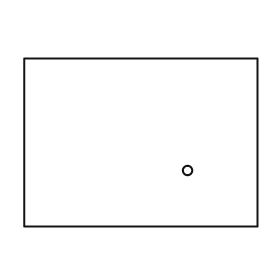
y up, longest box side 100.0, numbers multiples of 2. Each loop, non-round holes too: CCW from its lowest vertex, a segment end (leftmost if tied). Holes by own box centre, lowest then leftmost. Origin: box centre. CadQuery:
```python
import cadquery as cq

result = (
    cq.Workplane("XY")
    .moveTo(-50.0, -36.0)
    .lineTo(50.0, -36.0)
    .lineTo(50.0, 36.0)
    .lineTo(-50.0, 36.0)
    .close()
    .moveTo(20.0, -12.0)
    .circle(2.0)
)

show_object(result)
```